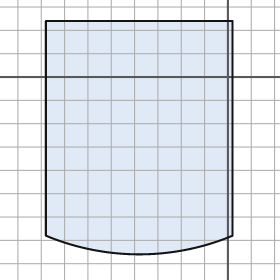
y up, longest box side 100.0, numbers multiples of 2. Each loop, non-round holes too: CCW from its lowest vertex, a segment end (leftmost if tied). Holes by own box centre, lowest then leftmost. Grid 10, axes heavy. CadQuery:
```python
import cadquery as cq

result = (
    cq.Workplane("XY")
    .moveTo(-78.0, -68.0)
    .threePointArc((-38.0, -76.0), (2.0, -68.0))
    .lineTo(2.0, 24.0)
    .lineTo(-78.0, 24.0)
    .close()
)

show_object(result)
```